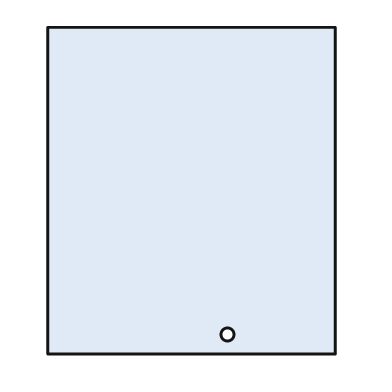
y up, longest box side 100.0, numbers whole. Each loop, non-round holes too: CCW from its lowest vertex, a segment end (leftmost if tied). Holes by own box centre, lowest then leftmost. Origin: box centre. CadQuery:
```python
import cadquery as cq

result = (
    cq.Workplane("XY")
    .moveTo(-44.0, -50.0)
    .lineTo(44.0, -50.0)
    .lineTo(44.0, 50.0)
    .lineTo(-44.0, 50.0)
    .close()
    .moveTo(11.0, -44.0)
    .circle(2.0)
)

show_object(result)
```